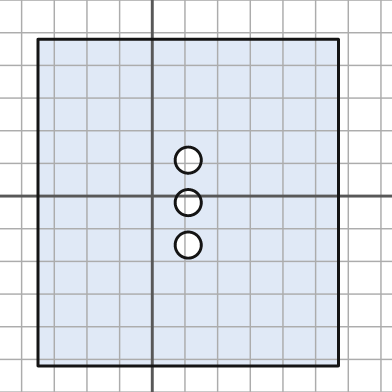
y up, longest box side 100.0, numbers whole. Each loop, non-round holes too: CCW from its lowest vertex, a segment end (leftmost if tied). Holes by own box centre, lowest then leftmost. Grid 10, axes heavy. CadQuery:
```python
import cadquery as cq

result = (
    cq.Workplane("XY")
    .moveTo(-35.0, -52.0)
    .lineTo(57.0, -52.0)
    .lineTo(57.0, 48.0)
    .lineTo(-35.0, 48.0)
    .close()
    .moveTo(11.0, -15.0)
    .circle(4.0)
    .moveTo(11.0, -2.0)
    .circle(4.0)
    .moveTo(11.0, 11.0)
    .circle(4.0)
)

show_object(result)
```